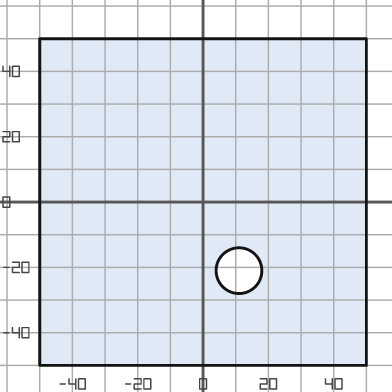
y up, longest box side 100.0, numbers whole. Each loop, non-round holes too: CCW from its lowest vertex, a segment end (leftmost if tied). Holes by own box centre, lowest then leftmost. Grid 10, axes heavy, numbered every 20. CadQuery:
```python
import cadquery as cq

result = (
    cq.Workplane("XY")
    .moveTo(-50.0, -50.0)
    .lineTo(50.0, -50.0)
    .lineTo(50.0, 50.0)
    .lineTo(-50.0, 50.0)
    .close()
    .moveTo(11.0, -21.0)
    .circle(7.0)
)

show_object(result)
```